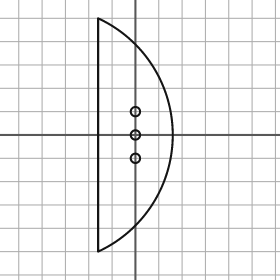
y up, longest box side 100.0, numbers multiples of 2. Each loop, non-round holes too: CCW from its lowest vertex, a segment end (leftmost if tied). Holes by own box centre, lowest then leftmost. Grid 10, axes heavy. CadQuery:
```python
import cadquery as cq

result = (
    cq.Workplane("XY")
    .moveTo(-16.0, -50.0)
    .threePointArc((16.0, 0.0), (-16.0, 50.0))
    .close()
    .moveTo(0.0, -10.0)
    .circle(2.0)
    .moveTo(0.0, 0.0)
    .circle(2.0)
    .moveTo(0.0, 10.0)
    .circle(2.0)
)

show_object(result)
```